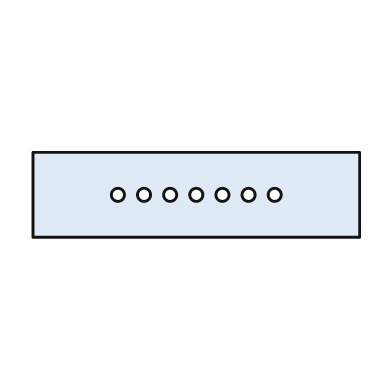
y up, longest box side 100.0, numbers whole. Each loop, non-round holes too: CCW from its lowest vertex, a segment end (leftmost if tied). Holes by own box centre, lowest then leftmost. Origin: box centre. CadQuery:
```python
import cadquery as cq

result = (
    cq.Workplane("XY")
    .moveTo(-50.0, -13.0)
    .lineTo(50.0, -13.0)
    .lineTo(50.0, 13.0)
    .lineTo(-50.0, 13.0)
    .close()
    .moveTo(-24.0, 0.0)
    .circle(2.0)
    .moveTo(-16.0, 0.0)
    .circle(2.0)
    .moveTo(-8.0, 0.0)
    .circle(2.0)
    .moveTo(0.0, 0.0)
    .circle(2.0)
    .moveTo(8.0, 0.0)
    .circle(2.0)
    .moveTo(16.0, 0.0)
    .circle(2.0)
    .moveTo(24.0, 0.0)
    .circle(2.0)
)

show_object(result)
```